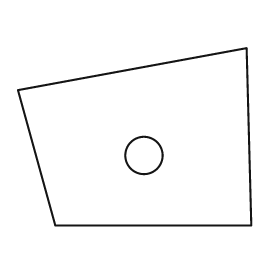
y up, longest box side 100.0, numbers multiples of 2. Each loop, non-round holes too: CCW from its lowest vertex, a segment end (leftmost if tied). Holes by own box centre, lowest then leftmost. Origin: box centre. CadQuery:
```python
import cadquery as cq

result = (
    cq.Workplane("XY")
    .moveTo(-34.0, -38.0)
    .lineTo(50.0, -38.0)
    .lineTo(48.0, 38.0)
    .lineTo(-50.0, 20.0)
    .close()
    .moveTo(4.0, -8.0)
    .circle(8.0)
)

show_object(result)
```